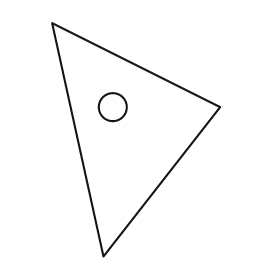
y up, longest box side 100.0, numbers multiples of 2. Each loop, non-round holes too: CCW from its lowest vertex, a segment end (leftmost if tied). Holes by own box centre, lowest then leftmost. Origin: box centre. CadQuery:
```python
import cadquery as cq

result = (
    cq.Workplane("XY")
    .moveTo(-14.0, -50.0)
    .lineTo(36.0, 14.0)
    .lineTo(-36.0, 50.0)
    .close()
    .moveTo(-10.0, 14.0)
    .circle(6.0)
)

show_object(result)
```